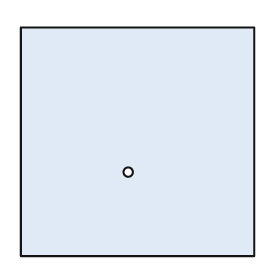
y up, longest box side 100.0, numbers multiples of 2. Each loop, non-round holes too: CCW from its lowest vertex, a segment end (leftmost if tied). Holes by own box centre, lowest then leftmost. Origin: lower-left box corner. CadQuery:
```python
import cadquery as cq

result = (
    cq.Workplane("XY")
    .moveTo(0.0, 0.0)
    .lineTo(100.0, 0.0)
    .lineTo(100.0, 98.0)
    .lineTo(0.0, 98.0)
    .close()
    .moveTo(46.0, 36.0)
    .circle(2.0)
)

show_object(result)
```